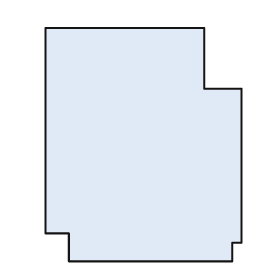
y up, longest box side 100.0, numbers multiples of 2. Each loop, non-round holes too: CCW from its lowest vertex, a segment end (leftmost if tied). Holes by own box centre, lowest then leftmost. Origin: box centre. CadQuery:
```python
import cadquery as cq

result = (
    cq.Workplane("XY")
    .moveTo(-32.0, -50.0)
    .lineTo(38.0, -50.0)
    .lineTo(38.0, -42.0)
    .lineTo(42.0, -42.0)
    .lineTo(42.0, 24.0)
    .lineTo(26.0, 24.0)
    .lineTo(26.0, 50.0)
    .lineTo(-42.0, 50.0)
    .lineTo(-42.0, -38.0)
    .lineTo(-32.0, -38.0)
    .close()
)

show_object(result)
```